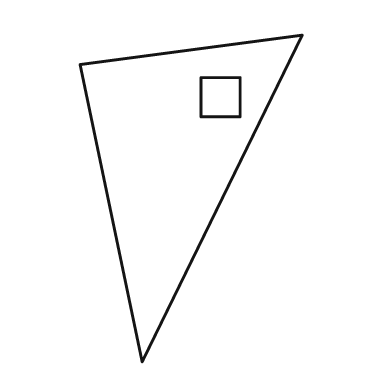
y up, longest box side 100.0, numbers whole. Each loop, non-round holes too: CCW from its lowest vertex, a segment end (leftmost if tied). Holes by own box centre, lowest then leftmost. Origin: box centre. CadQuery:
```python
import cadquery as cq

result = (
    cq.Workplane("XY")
    .moveTo(-15.0, -50.0)
    .lineTo(34.0, 50.0)
    .lineTo(-34.0, 41.0)
    .close()
    .moveTo(3.0, 25.0)
    .lineTo(15.0, 25.0)
    .lineTo(15.0, 37.0)
    .lineTo(3.0, 37.0)
    .close()
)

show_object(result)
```